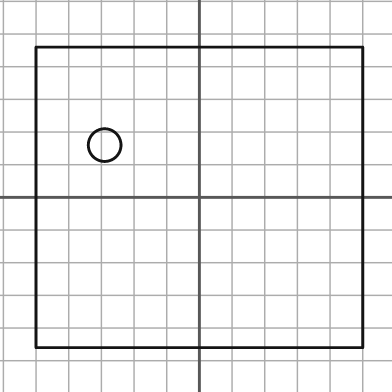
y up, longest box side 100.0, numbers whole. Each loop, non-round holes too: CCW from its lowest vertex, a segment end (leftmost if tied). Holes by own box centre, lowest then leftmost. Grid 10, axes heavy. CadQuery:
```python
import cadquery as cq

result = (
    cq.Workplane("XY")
    .moveTo(-50.0, -46.0)
    .lineTo(50.0, -46.0)
    .lineTo(50.0, 46.0)
    .lineTo(-50.0, 46.0)
    .close()
    .moveTo(-29.0, 16.0)
    .circle(5.0)
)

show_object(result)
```